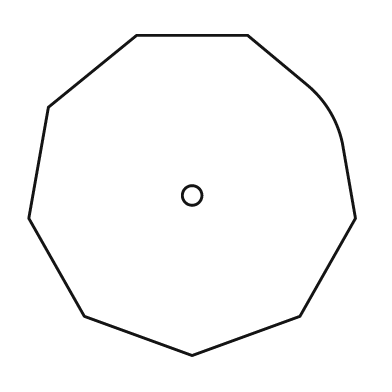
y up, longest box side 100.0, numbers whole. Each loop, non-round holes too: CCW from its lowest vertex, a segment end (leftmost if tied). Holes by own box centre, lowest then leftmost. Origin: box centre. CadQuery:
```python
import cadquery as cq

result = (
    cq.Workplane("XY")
    .moveTo(0.0, -49.0)
    .lineTo(33.0, -37.0)
    .lineTo(50.0, -7.0)
    .lineTo(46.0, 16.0)
    .threePointArc((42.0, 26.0), (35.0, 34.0))
    .lineTo(17.0, 49.0)
    .lineTo(-17.0, 49.0)
    .lineTo(-44.0, 27.0)
    .lineTo(-50.0, -7.0)
    .lineTo(-33.0, -37.0)
    .close()
    .moveTo(0.0, 0.0)
    .circle(3.0)
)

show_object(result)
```